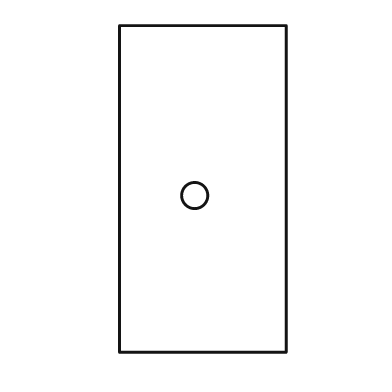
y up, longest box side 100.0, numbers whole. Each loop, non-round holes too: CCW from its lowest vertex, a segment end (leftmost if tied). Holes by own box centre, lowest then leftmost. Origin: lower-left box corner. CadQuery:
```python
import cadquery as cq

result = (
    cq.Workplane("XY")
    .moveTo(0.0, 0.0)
    .lineTo(51.0, 0.0)
    .lineTo(51.0, 100.0)
    .lineTo(0.0, 100.0)
    .close()
    .moveTo(23.0, 48.0)
    .circle(4.0)
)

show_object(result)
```